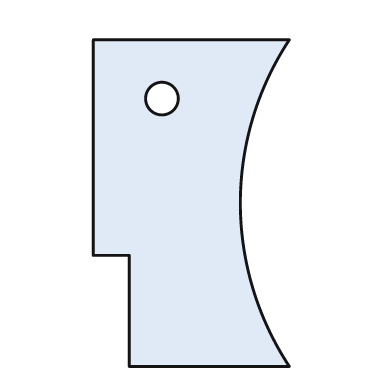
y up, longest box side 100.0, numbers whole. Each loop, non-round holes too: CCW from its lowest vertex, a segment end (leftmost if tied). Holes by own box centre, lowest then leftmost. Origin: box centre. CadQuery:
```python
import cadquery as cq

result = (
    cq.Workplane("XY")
    .moveTo(-19.0, -50.0)
    .lineTo(30.0, -50.0)
    .threePointArc((15.0, 0.0), (30.0, 50.0))
    .lineTo(-30.0, 50.0)
    .lineTo(-30.0, -16.0)
    .lineTo(-19.0, -16.0)
    .close()
    .moveTo(-9.0, 32.0)
    .circle(5.0)
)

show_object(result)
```